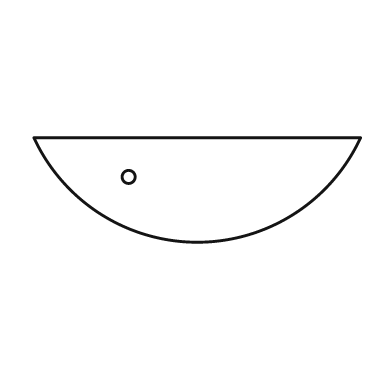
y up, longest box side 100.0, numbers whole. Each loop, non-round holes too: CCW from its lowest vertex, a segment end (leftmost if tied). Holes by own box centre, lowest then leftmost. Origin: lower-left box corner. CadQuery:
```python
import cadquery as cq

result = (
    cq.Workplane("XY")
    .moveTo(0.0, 32.0)
    .threePointArc((50.0, 0.0), (100.0, 32.0))
    .close()
    .moveTo(29.0, 20.0)
    .circle(2.0)
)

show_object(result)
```